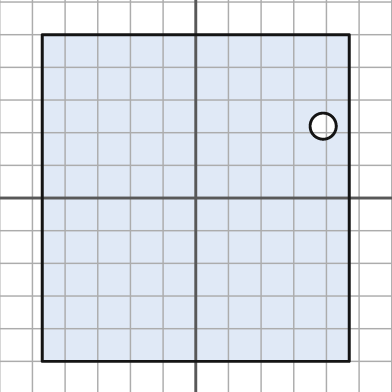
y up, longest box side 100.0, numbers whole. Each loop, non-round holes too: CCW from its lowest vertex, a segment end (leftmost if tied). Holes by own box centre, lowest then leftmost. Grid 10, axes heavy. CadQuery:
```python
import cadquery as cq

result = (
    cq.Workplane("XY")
    .moveTo(-47.0, -50.0)
    .lineTo(47.0, -50.0)
    .lineTo(47.0, 50.0)
    .lineTo(-47.0, 50.0)
    .close()
    .moveTo(39.0, 22.0)
    .circle(4.0)
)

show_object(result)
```